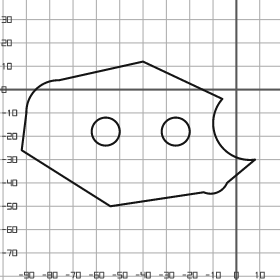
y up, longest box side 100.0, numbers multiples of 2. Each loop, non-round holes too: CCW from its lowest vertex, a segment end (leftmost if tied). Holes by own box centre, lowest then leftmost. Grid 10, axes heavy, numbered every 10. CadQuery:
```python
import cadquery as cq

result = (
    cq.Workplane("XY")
    .moveTo(-54.0, -50.0)
    .lineTo(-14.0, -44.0)
    .threePointArc((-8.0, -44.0), (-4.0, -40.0))
    .lineTo(8.0, -30.0)
    .threePointArc((-8.0, -22.0), (-6.0, -4.0))
    .lineTo(-40.0, 12.0)
    .lineTo(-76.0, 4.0)
    .threePointArc((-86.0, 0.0), (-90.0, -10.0))
    .lineTo(-92.0, -26.0)
    .close()
    .moveTo(-56.0, -18.0)
    .circle(6.0)
    .moveTo(-26.0, -18.0)
    .circle(6.0)
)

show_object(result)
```